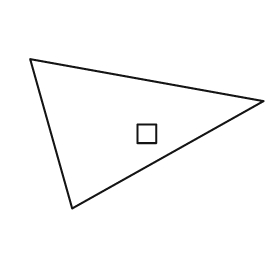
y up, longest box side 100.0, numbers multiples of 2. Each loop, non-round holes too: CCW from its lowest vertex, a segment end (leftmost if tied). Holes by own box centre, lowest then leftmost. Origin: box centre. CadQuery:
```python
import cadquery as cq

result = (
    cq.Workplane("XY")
    .moveTo(-32.0, -32.0)
    .lineTo(50.0, 14.0)
    .lineTo(-50.0, 32.0)
    .close()
    .moveTo(-4.0, -4.0)
    .lineTo(4.0, -4.0)
    .lineTo(4.0, 4.0)
    .lineTo(-4.0, 4.0)
    .close()
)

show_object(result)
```